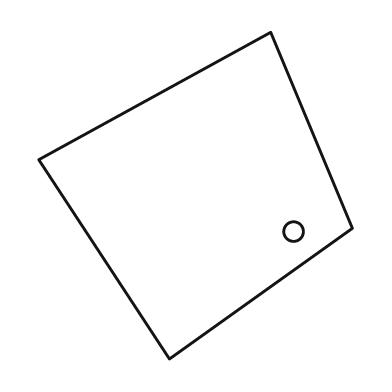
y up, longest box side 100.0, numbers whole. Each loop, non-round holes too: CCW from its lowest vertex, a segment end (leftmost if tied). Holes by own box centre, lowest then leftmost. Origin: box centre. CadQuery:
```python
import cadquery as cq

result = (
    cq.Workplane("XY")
    .moveTo(-8.0, -50.0)
    .lineTo(48.0, -10.0)
    .lineTo(23.0, 50.0)
    .lineTo(-48.0, 11.0)
    .close()
    .moveTo(30.0, -11.0)
    .circle(3.0)
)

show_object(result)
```